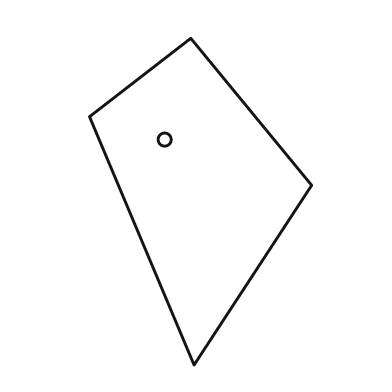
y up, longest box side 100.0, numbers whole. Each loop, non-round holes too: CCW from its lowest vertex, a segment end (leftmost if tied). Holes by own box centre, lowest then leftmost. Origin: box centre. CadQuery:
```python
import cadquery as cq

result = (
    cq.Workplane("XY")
    .moveTo(-2.0, -50.0)
    .lineTo(34.0, 5.0)
    .lineTo(-3.0, 50.0)
    .lineTo(-34.0, 26.0)
    .close()
    .moveTo(-11.0, 19.0)
    .circle(2.0)
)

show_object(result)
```